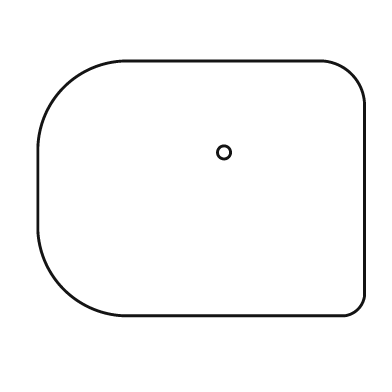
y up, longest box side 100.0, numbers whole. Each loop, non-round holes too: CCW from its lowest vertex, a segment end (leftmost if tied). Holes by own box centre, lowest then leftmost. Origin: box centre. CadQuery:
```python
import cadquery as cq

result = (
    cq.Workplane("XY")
    .moveTo(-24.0, -39.0)
    .lineTo(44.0, -39.0)
    .threePointArc((48.0, -37.0), (50.0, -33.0))
    .lineTo(50.0, 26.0)
    .threePointArc((46.0, 35.0), (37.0, 39.0))
    .lineTo(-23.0, 39.0)
    .threePointArc((-42.0, 31.0), (-50.0, 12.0))
    .lineTo(-50.0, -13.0)
    .threePointArc((-42.0, -31.0), (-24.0, -39.0))
    .close()
    .moveTo(7.0, 11.0)
    .circle(2.0)
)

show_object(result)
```